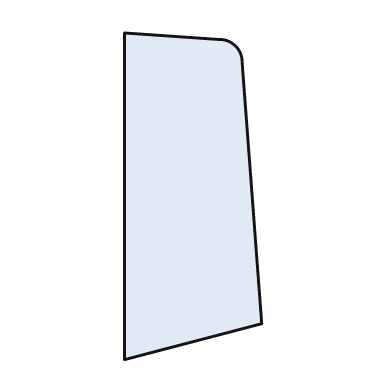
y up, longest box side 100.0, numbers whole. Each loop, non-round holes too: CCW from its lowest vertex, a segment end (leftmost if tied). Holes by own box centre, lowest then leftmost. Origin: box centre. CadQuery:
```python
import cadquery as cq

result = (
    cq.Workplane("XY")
    .moveTo(-21.0, -50.0)
    .lineTo(21.0, -39.0)
    .lineTo(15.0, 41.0)
    .threePointArc((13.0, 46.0), (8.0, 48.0))
    .lineTo(-21.0, 50.0)
    .close()
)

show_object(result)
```